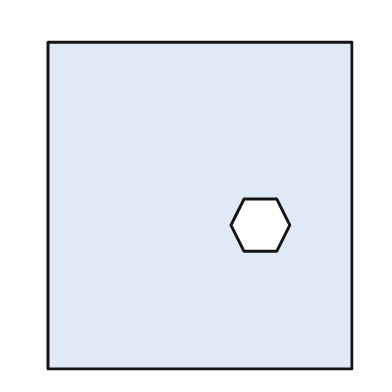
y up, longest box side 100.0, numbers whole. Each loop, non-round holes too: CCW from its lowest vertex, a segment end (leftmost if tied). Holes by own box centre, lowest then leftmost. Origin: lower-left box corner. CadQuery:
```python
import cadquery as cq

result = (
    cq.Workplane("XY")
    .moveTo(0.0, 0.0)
    .lineTo(93.0, 0.0)
    .lineTo(93.0, 100.0)
    .lineTo(0.0, 100.0)
    .close()
    .moveTo(60.0, 36.0)
    .lineTo(70.0, 36.0)
    .lineTo(74.0, 44.0)
    .lineTo(70.0, 52.0)
    .lineTo(60.0, 52.0)
    .lineTo(56.0, 44.0)
    .close()
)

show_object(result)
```